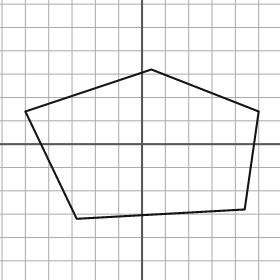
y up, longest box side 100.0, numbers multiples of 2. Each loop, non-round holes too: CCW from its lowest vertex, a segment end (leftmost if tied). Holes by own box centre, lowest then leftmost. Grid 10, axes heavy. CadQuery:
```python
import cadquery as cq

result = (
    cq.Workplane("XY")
    .moveTo(-28.0, -32.0)
    .lineTo(44.0, -28.0)
    .lineTo(50.0, 14.0)
    .lineTo(4.0, 32.0)
    .lineTo(-50.0, 14.0)
    .close()
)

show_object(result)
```